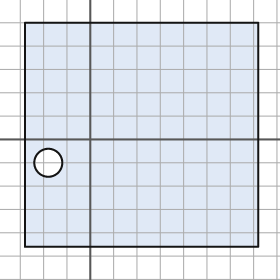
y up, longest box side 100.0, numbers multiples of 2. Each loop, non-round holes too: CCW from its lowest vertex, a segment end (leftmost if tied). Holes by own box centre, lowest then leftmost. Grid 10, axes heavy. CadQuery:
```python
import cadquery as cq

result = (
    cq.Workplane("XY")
    .moveTo(-28.0, -46.0)
    .lineTo(72.0, -46.0)
    .lineTo(72.0, 50.0)
    .lineTo(-28.0, 50.0)
    .close()
    .moveTo(-18.0, -10.0)
    .circle(6.0)
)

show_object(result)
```